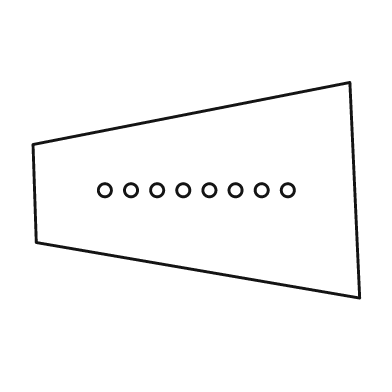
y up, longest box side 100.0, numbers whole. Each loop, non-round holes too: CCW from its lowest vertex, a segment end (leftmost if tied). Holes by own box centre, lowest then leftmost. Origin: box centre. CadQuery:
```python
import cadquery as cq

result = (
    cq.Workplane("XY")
    .moveTo(50.0, -33.0)
    .lineTo(47.0, 33.0)
    .lineTo(-50.0, 14.0)
    .lineTo(-49.0, -16.0)
    .close()
    .moveTo(-28.0, 0.0)
    .circle(2.0)
    .moveTo(-20.0, 0.0)
    .circle(2.0)
    .moveTo(-12.0, 0.0)
    .circle(2.0)
    .moveTo(-4.0, 0.0)
    .circle(2.0)
    .moveTo(4.0, 0.0)
    .circle(2.0)
    .moveTo(12.0, 0.0)
    .circle(2.0)
    .moveTo(20.0, 0.0)
    .circle(2.0)
    .moveTo(28.0, 0.0)
    .circle(2.0)
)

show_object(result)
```